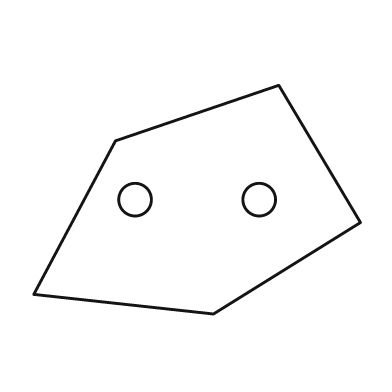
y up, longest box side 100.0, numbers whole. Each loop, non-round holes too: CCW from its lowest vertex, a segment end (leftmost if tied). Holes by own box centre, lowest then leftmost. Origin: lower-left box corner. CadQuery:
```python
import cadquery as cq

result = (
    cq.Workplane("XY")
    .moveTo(55.0, 0.0)
    .lineTo(100.0, 28.0)
    .lineTo(75.0, 70.0)
    .lineTo(25.0, 53.0)
    .lineTo(0.0, 6.0)
    .close()
    .moveTo(31.0, 35.0)
    .circle(5.0)
    .moveTo(69.0, 35.0)
    .circle(5.0)
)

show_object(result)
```